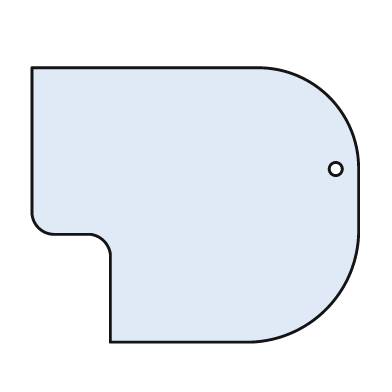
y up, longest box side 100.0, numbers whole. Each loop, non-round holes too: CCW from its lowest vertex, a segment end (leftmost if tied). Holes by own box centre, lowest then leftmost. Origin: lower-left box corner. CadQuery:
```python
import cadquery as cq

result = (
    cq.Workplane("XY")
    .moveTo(24.0, 0.0)
    .lineTo(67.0, 0.0)
    .threePointArc((90.0, 10.0), (100.0, 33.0))
    .lineTo(100.0, 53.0)
    .threePointArc((91.0, 75.0), (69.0, 84.0))
    .lineTo(0.0, 84.0)
    .lineTo(0.0, 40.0)
    .threePointArc((2.0, 35.0), (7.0, 33.0))
    .lineTo(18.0, 33.0)
    .threePointArc((22.0, 31.0), (24.0, 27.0))
    .close()
    .moveTo(93.0, 53.0)
    .circle(2.0)
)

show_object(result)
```